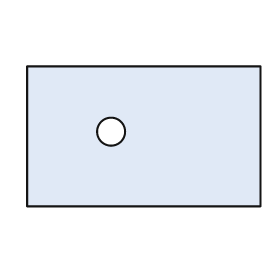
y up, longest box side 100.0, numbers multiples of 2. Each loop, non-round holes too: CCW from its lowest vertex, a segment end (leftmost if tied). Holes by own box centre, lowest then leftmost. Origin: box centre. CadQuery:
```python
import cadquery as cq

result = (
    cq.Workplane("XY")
    .moveTo(-50.0, -30.0)
    .lineTo(50.0, -30.0)
    .lineTo(50.0, 30.0)
    .lineTo(-50.0, 30.0)
    .close()
    .moveTo(-14.0, 2.0)
    .circle(6.0)
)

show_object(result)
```